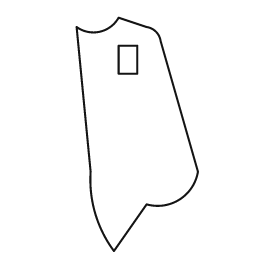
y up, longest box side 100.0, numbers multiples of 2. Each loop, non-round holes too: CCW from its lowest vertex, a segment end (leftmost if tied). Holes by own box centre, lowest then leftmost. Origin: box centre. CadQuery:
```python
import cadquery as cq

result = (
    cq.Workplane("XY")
    .moveTo(-10.0, -50.0)
    .lineTo(4.0, -30.0)
    .threePointArc((18.0, -28.0), (26.0, -16.0))
    .lineTo(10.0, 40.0)
    .threePointArc((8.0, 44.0), (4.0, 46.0))
    .lineTo(-8.0, 50.0)
    .threePointArc((-16.0, 44.0), (-26.0, 46.0))
    .lineTo(-20.0, -16.0)
    .threePointArc((-18.0, -34.0), (-10.0, -50.0))
    .close()
    .moveTo(-8.0, 26.0)
    .lineTo(0.0, 26.0)
    .lineTo(0.0, 38.0)
    .lineTo(-8.0, 38.0)
    .close()
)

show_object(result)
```